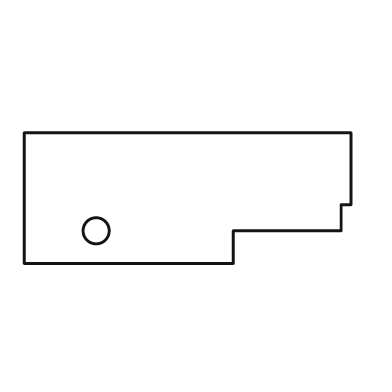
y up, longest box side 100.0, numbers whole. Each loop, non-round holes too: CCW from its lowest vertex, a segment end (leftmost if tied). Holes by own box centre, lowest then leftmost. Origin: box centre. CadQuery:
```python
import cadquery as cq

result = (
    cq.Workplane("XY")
    .moveTo(-50.0, -20.0)
    .lineTo(14.0, -20.0)
    .lineTo(14.0, -10.0)
    .lineTo(47.0, -10.0)
    .lineTo(47.0, -2.0)
    .lineTo(50.0, -2.0)
    .lineTo(50.0, 20.0)
    .lineTo(-50.0, 20.0)
    .close()
    .moveTo(-28.0, -10.0)
    .circle(4.0)
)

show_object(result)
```